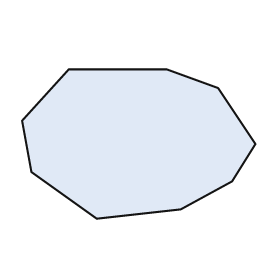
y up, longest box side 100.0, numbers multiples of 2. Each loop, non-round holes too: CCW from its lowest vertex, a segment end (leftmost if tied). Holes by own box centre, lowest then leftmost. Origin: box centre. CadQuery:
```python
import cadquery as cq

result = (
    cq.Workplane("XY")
    .moveTo(-18.0, -32.0)
    .lineTo(18.0, -28.0)
    .lineTo(40.0, -16.0)
    .lineTo(50.0, 0.0)
    .lineTo(34.0, 24.0)
    .lineTo(12.0, 32.0)
    .lineTo(-30.0, 32.0)
    .lineTo(-50.0, 10.0)
    .lineTo(-46.0, -12.0)
    .close()
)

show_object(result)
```